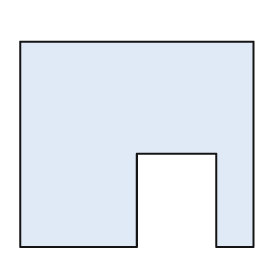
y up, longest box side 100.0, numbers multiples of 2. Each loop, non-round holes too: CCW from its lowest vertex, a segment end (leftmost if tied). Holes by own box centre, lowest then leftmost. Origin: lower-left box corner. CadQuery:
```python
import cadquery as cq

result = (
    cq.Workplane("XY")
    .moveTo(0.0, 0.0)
    .lineTo(50.0, 0.0)
    .lineTo(50.0, 40.0)
    .lineTo(84.0, 40.0)
    .lineTo(84.0, 0.0)
    .lineTo(100.0, 0.0)
    .lineTo(100.0, 88.0)
    .lineTo(0.0, 88.0)
    .close()
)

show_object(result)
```